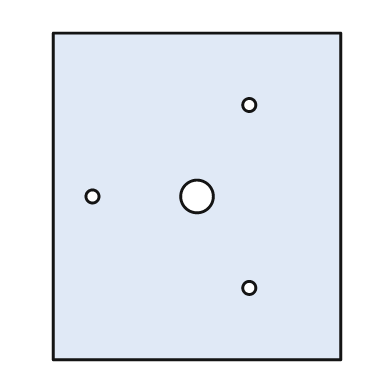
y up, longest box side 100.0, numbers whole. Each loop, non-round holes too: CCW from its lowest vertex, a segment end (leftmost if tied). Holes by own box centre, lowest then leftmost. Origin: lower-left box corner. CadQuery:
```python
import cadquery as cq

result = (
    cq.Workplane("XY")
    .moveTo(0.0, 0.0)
    .lineTo(88.0, 0.0)
    .lineTo(88.0, 100.0)
    .lineTo(0.0, 100.0)
    .close()
    .moveTo(60.0, 22.0)
    .circle(2.0)
    .moveTo(12.0, 50.0)
    .circle(2.0)
    .moveTo(44.0, 50.0)
    .circle(5.0)
    .moveTo(60.0, 78.0)
    .circle(2.0)
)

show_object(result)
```